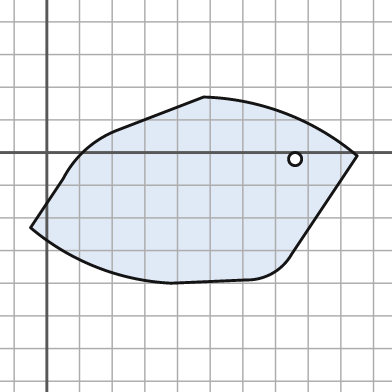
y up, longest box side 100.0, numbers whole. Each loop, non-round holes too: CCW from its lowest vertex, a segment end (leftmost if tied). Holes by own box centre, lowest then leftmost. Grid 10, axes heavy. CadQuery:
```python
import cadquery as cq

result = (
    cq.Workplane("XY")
    .moveTo(38.0, -40.0)
    .lineTo(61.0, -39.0)
    .threePointArc((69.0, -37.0), (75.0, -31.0))
    .lineTo(95.0, -1.0)
    .threePointArc((73.0, 12.0), (48.0, 17.0))
    .lineTo(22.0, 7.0)
    .threePointArc((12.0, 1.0), (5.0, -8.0))
    .lineTo(-5.0, -23.0)
    .threePointArc((15.0, -35.0), (38.0, -40.0))
    .close()
    .moveTo(76.0, -2.0)
    .circle(2.0)
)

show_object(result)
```